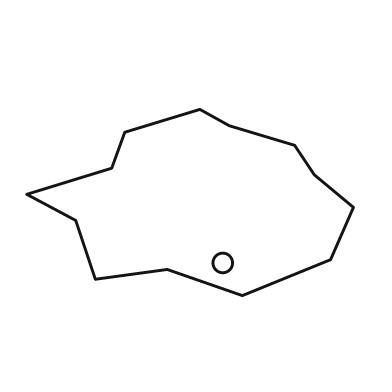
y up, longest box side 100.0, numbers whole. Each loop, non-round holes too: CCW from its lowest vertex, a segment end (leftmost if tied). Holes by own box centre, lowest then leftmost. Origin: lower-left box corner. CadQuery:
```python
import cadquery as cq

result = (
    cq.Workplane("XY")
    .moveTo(66.0, 0.0)
    .lineTo(93.0, 11.0)
    .lineTo(100.0, 27.0)
    .lineTo(88.0, 37.0)
    .lineTo(82.0, 46.0)
    .lineTo(62.0, 52.0)
    .lineTo(53.0, 57.0)
    .lineTo(30.0, 50.0)
    .lineTo(26.0, 39.0)
    .lineTo(0.0, 31.0)
    .lineTo(15.0, 23.0)
    .lineTo(21.0, 5.0)
    .lineTo(43.0, 8.0)
    .close()
    .moveTo(60.0, 10.0)
    .circle(3.0)
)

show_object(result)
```